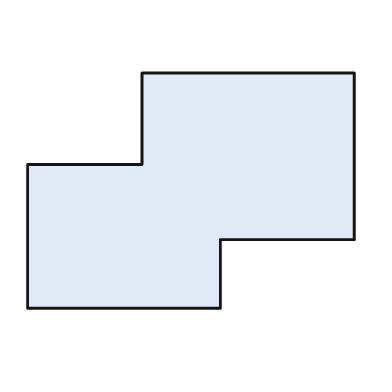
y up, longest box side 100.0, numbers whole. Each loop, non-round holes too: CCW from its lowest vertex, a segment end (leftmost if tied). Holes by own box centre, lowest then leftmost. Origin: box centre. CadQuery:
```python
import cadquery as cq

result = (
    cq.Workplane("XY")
    .moveTo(-50.0, -36.0)
    .lineTo(9.0, -36.0)
    .lineTo(9.0, -15.0)
    .lineTo(50.0, -15.0)
    .lineTo(50.0, 36.0)
    .lineTo(-15.0, 36.0)
    .lineTo(-15.0, 8.0)
    .lineTo(-50.0, 8.0)
    .close()
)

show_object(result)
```